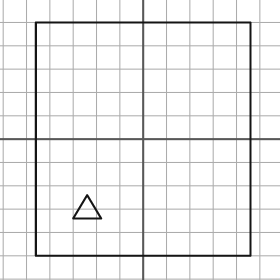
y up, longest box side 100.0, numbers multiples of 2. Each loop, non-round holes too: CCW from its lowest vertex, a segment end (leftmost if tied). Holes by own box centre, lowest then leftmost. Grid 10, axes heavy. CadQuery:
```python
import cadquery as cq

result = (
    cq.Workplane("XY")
    .moveTo(-46.0, -50.0)
    .lineTo(46.0, -50.0)
    .lineTo(46.0, 50.0)
    .lineTo(-46.0, 50.0)
    .close()
    .moveTo(-30.0, -34.0)
    .lineTo(-18.0, -34.0)
    .lineTo(-24.0, -24.0)
    .close()
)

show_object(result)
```